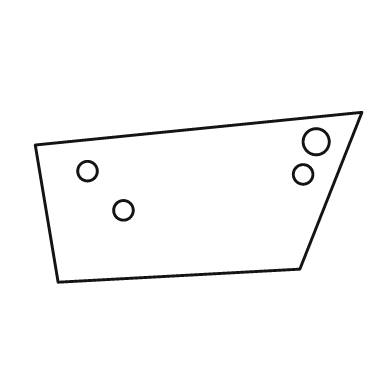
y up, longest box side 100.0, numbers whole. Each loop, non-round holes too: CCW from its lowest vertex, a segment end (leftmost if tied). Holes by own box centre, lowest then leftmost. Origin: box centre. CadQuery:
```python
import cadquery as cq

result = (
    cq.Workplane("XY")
    .moveTo(-43.0, -26.0)
    .lineTo(31.0, -22.0)
    .lineTo(50.0, 26.0)
    .lineTo(-50.0, 16.0)
    .close()
    .moveTo(-23.0, -4.0)
    .circle(3.0)
    .moveTo(32.0, 7.0)
    .circle(3.0)
    .moveTo(-34.0, 8.0)
    .circle(3.0)
    .moveTo(36.0, 17.0)
    .circle(4.0)
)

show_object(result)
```